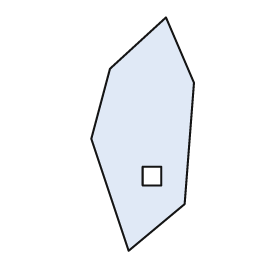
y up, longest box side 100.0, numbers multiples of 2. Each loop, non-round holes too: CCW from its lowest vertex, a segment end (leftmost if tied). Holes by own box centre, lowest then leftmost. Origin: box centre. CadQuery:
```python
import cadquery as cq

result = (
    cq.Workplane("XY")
    .moveTo(-6.0, -50.0)
    .lineTo(18.0, -30.0)
    .lineTo(22.0, 22.0)
    .lineTo(10.0, 50.0)
    .lineTo(-14.0, 28.0)
    .lineTo(-22.0, -2.0)
    .close()
    .moveTo(0.0, -22.0)
    .lineTo(8.0, -22.0)
    .lineTo(8.0, -14.0)
    .lineTo(0.0, -14.0)
    .close()
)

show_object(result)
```